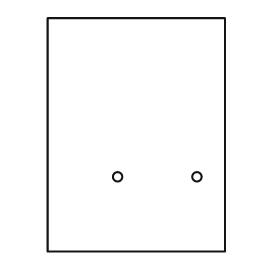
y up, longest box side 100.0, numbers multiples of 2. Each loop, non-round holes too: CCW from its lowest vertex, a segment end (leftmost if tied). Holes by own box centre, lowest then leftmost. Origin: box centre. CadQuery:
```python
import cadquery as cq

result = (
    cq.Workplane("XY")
    .moveTo(-38.0, -50.0)
    .lineTo(38.0, -50.0)
    .lineTo(38.0, 50.0)
    .lineTo(-38.0, 50.0)
    .close()
    .moveTo(-8.0, -18.0)
    .circle(2.0)
    .moveTo(26.0, -18.0)
    .circle(2.0)
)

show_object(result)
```